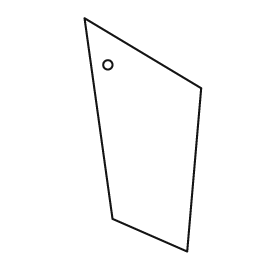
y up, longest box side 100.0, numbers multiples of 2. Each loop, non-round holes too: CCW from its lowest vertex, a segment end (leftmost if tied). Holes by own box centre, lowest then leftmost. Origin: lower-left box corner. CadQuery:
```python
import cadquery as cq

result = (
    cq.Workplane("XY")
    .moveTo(44.0, 0.0)
    .lineTo(50.0, 70.0)
    .lineTo(0.0, 100.0)
    .lineTo(12.0, 14.0)
    .close()
    .moveTo(10.0, 80.0)
    .circle(2.0)
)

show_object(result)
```